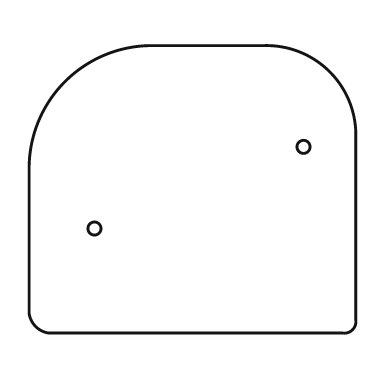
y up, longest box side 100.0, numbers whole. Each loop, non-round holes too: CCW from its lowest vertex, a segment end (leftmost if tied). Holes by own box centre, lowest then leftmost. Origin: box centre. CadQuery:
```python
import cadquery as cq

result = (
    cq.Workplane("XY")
    .moveTo(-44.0, -44.0)
    .lineTo(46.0, -44.0)
    .threePointArc((49.0, -43.0), (50.0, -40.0))
    .lineTo(50.0, 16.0)
    .threePointArc((42.0, 36.0), (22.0, 44.0))
    .lineTo(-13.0, 44.0)
    .threePointArc((-39.0, 33.0), (-50.0, 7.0))
    .lineTo(-50.0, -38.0)
    .threePointArc((-48.0, -42.0), (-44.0, -44.0))
    .close()
    .moveTo(-30.0, -12.0)
    .circle(2.0)
    .moveTo(34.0, 13.0)
    .circle(2.0)
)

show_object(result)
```